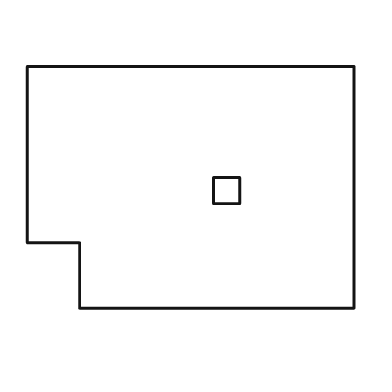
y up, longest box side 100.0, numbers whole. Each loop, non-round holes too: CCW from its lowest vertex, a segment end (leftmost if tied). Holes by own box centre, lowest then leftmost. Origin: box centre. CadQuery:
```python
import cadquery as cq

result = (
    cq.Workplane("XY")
    .moveTo(-34.0, -37.0)
    .lineTo(50.0, -37.0)
    .lineTo(50.0, 37.0)
    .lineTo(-50.0, 37.0)
    .lineTo(-50.0, -17.0)
    .lineTo(-34.0, -17.0)
    .close()
    .moveTo(7.0, -5.0)
    .lineTo(15.0, -5.0)
    .lineTo(15.0, 3.0)
    .lineTo(7.0, 3.0)
    .close()
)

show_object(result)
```